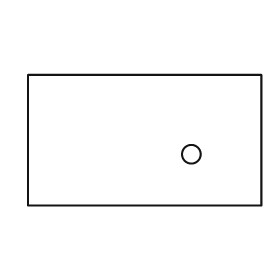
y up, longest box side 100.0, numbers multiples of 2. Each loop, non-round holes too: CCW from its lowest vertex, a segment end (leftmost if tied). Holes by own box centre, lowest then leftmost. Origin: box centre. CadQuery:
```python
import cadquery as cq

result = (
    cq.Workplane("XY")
    .moveTo(-50.0, -28.0)
    .lineTo(50.0, -28.0)
    .lineTo(50.0, 28.0)
    .lineTo(-50.0, 28.0)
    .close()
    .moveTo(20.0, -6.0)
    .circle(4.0)
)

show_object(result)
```